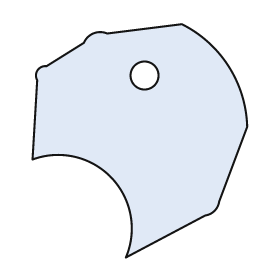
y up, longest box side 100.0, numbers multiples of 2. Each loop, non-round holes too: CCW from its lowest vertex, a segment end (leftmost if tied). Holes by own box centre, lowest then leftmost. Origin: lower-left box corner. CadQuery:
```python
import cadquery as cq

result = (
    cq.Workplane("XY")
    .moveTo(40.0, 0.0)
    .lineTo(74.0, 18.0)
    .threePointArc((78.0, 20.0), (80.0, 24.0))
    .lineTo(92.0, 56.0)
    .threePointArc((84.0, 82.0), (64.0, 100.0))
    .lineTo(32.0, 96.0)
    .threePointArc((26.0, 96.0), (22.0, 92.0))
    .lineTo(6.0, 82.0)
    .threePointArc((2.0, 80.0), (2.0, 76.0))
    .lineTo(0.0, 42.0)
    .threePointArc((34.0, 34.0), (40.0, 0.0))
    .close()
    .moveTo(48.0, 78.0)
    .circle(6.0)
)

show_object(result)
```